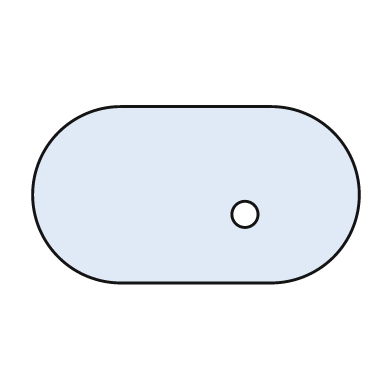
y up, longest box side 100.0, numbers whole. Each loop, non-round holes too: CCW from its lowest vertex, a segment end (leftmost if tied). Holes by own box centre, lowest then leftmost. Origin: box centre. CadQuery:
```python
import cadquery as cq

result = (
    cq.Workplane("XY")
    .moveTo(-23.0, -27.0)
    .lineTo(23.0, -27.0)
    .threePointArc((50.0, 0.0), (23.0, 27.0))
    .lineTo(-23.0, 27.0)
    .threePointArc((-50.0, 0.0), (-23.0, -27.0))
    .close()
    .moveTo(15.0, -6.0)
    .circle(4.0)
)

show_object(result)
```